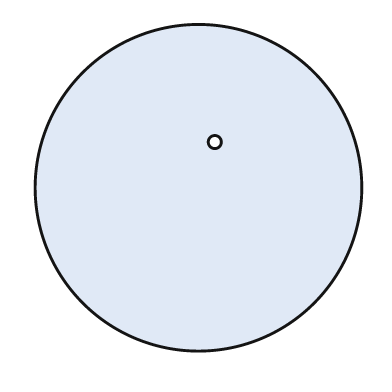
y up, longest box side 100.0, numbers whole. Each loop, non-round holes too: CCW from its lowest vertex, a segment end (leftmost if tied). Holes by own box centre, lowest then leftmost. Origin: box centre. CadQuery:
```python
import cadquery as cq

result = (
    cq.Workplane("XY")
    .moveTo(0.0, 0.0)
    .circle(50.0)
    .moveTo(5.0, 14.0)
    .circle(2.0)
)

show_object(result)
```